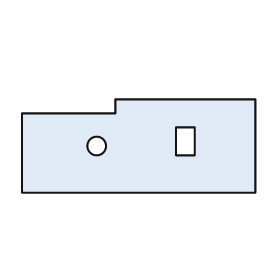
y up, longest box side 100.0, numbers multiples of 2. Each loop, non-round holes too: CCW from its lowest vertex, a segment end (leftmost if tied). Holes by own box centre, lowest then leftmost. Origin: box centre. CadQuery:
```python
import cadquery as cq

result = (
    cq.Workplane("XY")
    .moveTo(-50.0, -20.0)
    .lineTo(50.0, -20.0)
    .lineTo(50.0, 20.0)
    .lineTo(-10.0, 20.0)
    .lineTo(-10.0, 14.0)
    .lineTo(-50.0, 14.0)
    .close()
    .moveTo(-18.0, 0.0)
    .circle(4.0)
    .moveTo(16.0, -4.0)
    .lineTo(24.0, -4.0)
    .lineTo(24.0, 8.0)
    .lineTo(16.0, 8.0)
    .close()
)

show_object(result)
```